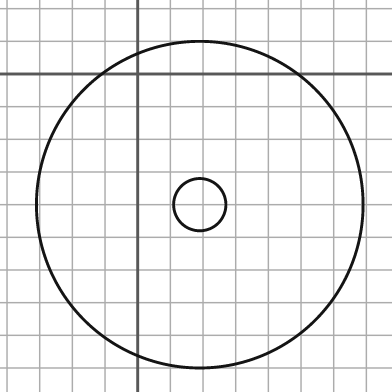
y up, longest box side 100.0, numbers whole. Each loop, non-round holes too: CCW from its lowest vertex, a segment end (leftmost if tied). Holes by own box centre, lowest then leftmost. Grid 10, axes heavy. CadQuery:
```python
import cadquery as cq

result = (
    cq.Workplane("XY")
    .moveTo(19.0, -40.0)
    .circle(50.0)
    .moveTo(19.0, -40.0)
    .circle(8.0)
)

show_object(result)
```